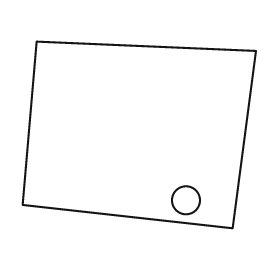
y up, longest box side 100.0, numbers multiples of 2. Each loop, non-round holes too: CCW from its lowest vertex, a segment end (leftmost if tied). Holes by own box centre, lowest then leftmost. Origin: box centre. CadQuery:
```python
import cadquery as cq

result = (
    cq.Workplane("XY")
    .moveTo(40.0, -40.0)
    .lineTo(50.0, 36.0)
    .lineTo(-44.0, 40.0)
    .lineTo(-50.0, -30.0)
    .close()
    .moveTo(20.0, -28.0)
    .circle(6.0)
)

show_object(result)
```